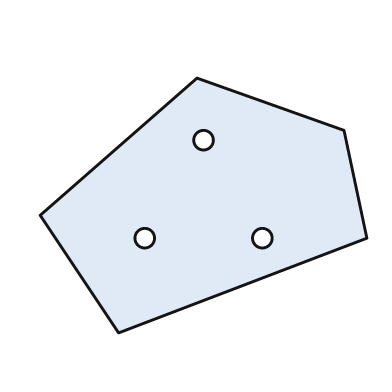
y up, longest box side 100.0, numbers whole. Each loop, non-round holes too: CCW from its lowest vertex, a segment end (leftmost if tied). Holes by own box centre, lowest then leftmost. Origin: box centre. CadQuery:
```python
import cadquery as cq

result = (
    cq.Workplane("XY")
    .moveTo(-26.0, -39.0)
    .lineTo(50.0, -10.0)
    .lineTo(43.0, 23.0)
    .lineTo(-2.0, 39.0)
    .lineTo(-50.0, -3.0)
    .close()
    .moveTo(-18.0, -10.0)
    .circle(3.0)
    .moveTo(18.0, -10.0)
    .circle(3.0)
    .moveTo(0.0, 20.0)
    .circle(3.0)
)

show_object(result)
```